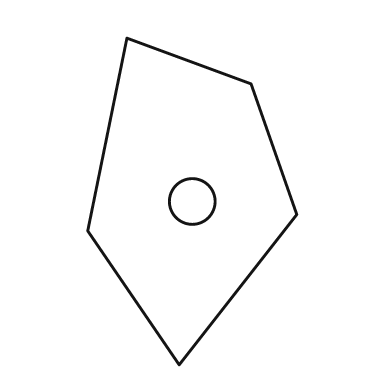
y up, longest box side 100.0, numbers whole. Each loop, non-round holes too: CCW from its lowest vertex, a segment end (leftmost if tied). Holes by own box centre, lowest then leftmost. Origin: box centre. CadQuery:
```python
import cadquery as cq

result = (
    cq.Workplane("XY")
    .moveTo(-4.0, -50.0)
    .lineTo(32.0, -4.0)
    .lineTo(18.0, 36.0)
    .lineTo(-20.0, 50.0)
    .lineTo(-32.0, -9.0)
    .close()
    .moveTo(0.0, 0.0)
    .circle(7.0)
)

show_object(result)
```